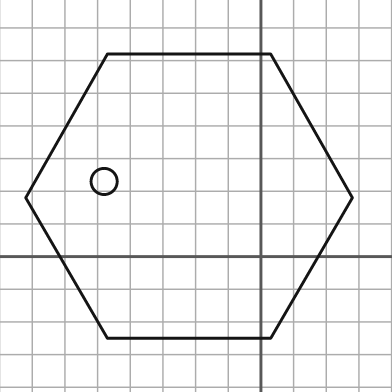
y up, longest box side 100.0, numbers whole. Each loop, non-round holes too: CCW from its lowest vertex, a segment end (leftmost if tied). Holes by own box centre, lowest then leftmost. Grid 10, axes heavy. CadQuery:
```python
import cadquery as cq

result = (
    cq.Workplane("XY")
    .moveTo(-47.0, -25.0)
    .lineTo(3.0, -25.0)
    .lineTo(28.0, 18.0)
    .lineTo(3.0, 62.0)
    .lineTo(-47.0, 62.0)
    .lineTo(-72.0, 18.0)
    .close()
    .moveTo(-48.0, 23.0)
    .circle(4.0)
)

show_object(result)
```